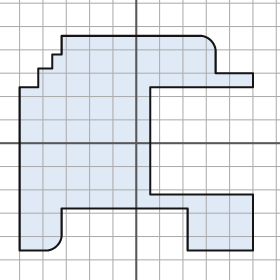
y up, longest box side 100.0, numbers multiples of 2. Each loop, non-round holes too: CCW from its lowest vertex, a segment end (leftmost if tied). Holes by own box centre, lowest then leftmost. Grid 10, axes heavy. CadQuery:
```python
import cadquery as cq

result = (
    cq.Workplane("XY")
    .moveTo(-50.0, -46.0)
    .lineTo(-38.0, -46.0)
    .threePointArc((-34.0, -44.0), (-32.0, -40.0))
    .lineTo(-32.0, -28.0)
    .lineTo(22.0, -28.0)
    .lineTo(22.0, -46.0)
    .lineTo(50.0, -46.0)
    .lineTo(50.0, -22.0)
    .lineTo(6.0, -22.0)
    .lineTo(6.0, 24.0)
    .lineTo(50.0, 24.0)
    .lineTo(50.0, 30.0)
    .lineTo(34.0, 30.0)
    .lineTo(34.0, 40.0)
    .threePointArc((32.0, 44.0), (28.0, 46.0))
    .lineTo(-32.0, 46.0)
    .lineTo(-32.0, 38.0)
    .lineTo(-36.0, 38.0)
    .lineTo(-36.0, 32.0)
    .lineTo(-42.0, 32.0)
    .lineTo(-42.0, 24.0)
    .lineTo(-50.0, 24.0)
    .close()
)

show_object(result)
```